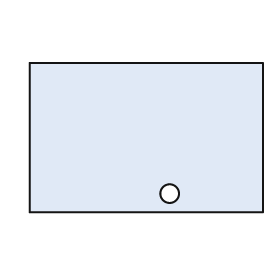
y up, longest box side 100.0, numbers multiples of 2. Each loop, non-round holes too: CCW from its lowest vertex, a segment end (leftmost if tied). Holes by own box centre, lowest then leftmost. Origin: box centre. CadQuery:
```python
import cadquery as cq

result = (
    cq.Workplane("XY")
    .moveTo(-50.0, -32.0)
    .lineTo(50.0, -32.0)
    .lineTo(50.0, 32.0)
    .lineTo(-50.0, 32.0)
    .close()
    .moveTo(10.0, -24.0)
    .circle(4.0)
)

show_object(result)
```